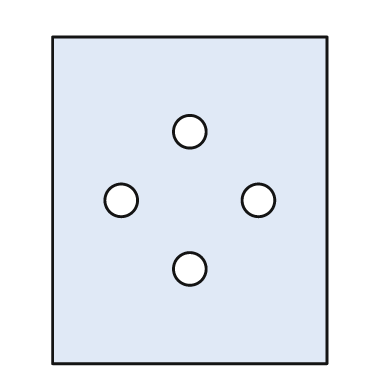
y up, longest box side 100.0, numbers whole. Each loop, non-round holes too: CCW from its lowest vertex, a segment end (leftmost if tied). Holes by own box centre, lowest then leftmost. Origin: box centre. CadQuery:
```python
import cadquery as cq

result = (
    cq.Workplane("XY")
    .moveTo(-42.0, -50.0)
    .lineTo(42.0, -50.0)
    .lineTo(42.0, 50.0)
    .lineTo(-42.0, 50.0)
    .close()
    .moveTo(0.0, -21.0)
    .circle(5.0)
    .moveTo(-21.0, 0.0)
    .circle(5.0)
    .moveTo(21.0, 0.0)
    .circle(5.0)
    .moveTo(0.0, 21.0)
    .circle(5.0)
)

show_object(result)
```